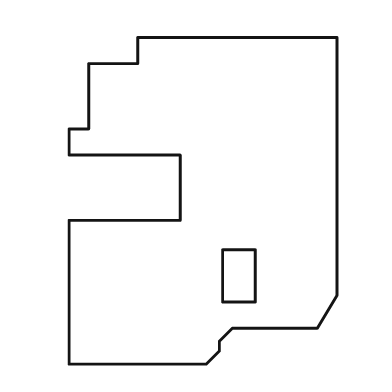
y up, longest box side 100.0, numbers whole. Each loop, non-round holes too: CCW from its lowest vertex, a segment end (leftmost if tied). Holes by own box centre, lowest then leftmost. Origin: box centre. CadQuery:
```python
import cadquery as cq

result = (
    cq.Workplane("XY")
    .moveTo(-41.0, -50.0)
    .lineTo(1.0, -50.0)
    .lineTo(5.0, -46.0)
    .lineTo(5.0, -43.0)
    .lineTo(9.0, -39.0)
    .lineTo(35.0, -39.0)
    .lineTo(41.0, -29.0)
    .lineTo(41.0, 50.0)
    .lineTo(-20.0, 50.0)
    .lineTo(-20.0, 42.0)
    .lineTo(-35.0, 42.0)
    .lineTo(-35.0, 22.0)
    .lineTo(-41.0, 22.0)
    .lineTo(-41.0, 14.0)
    .lineTo(-7.0, 14.0)
    .lineTo(-7.0, -6.0)
    .lineTo(-41.0, -6.0)
    .close()
    .moveTo(6.0, -31.0)
    .lineTo(16.0, -31.0)
    .lineTo(16.0, -15.0)
    .lineTo(6.0, -15.0)
    .close()
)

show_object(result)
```